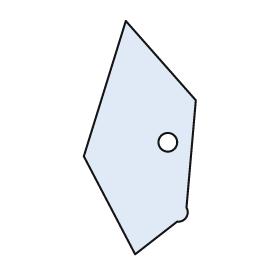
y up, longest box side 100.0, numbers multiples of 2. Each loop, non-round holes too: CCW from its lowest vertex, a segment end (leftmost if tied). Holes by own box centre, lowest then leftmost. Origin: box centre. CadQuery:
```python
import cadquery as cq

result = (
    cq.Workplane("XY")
    .moveTo(-2.0, -50.0)
    .lineTo(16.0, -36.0)
    .threePointArc((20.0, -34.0), (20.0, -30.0))
    .lineTo(24.0, 16.0)
    .lineTo(-6.0, 50.0)
    .lineTo(-24.0, -8.0)
    .close()
    .moveTo(12.0, -2.0)
    .circle(4.0)
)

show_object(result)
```